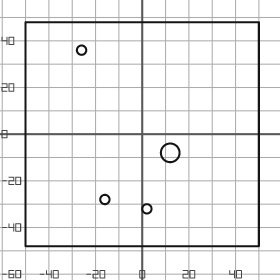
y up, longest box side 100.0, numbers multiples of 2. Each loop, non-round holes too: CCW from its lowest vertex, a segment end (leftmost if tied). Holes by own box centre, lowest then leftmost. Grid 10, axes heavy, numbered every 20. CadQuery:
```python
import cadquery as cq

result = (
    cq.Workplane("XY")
    .moveTo(-50.0, -48.0)
    .lineTo(50.0, -48.0)
    .lineTo(50.0, 48.0)
    .lineTo(-50.0, 48.0)
    .close()
    .moveTo(2.0, -32.0)
    .circle(2.0)
    .moveTo(-16.0, -28.0)
    .circle(2.0)
    .moveTo(12.0, -8.0)
    .circle(4.0)
    .moveTo(-26.0, 36.0)
    .circle(2.0)
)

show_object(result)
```